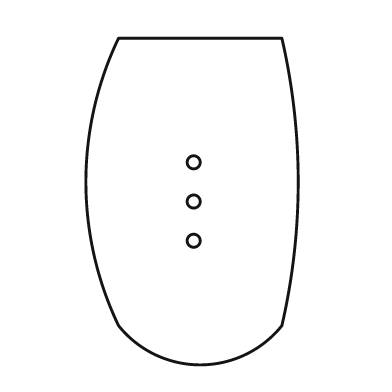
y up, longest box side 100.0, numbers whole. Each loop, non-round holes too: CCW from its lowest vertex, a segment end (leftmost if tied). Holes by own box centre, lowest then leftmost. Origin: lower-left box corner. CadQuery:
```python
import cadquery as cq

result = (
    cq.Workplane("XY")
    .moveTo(10.0, 12.0)
    .threePointArc((35.0, 0.0), (60.0, 12.0))
    .threePointArc((65.0, 56.0), (60.0, 100.0))
    .lineTo(10.0, 100.0)
    .threePointArc((0.0, 56.0), (10.0, 12.0))
    .close()
    .moveTo(33.0, 38.0)
    .circle(2.0)
    .moveTo(33.0, 50.0)
    .circle(2.0)
    .moveTo(33.0, 62.0)
    .circle(2.0)
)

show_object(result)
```